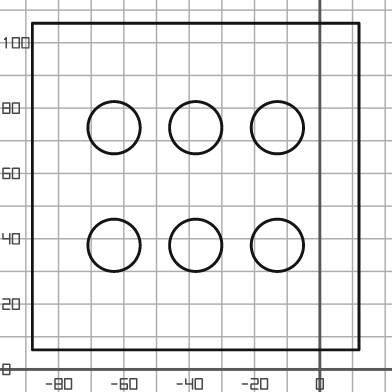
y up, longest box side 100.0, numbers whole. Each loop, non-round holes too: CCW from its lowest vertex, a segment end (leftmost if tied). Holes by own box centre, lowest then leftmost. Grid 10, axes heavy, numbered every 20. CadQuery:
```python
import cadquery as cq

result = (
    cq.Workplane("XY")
    .moveTo(-88.0, 6.0)
    .lineTo(12.0, 6.0)
    .lineTo(12.0, 106.0)
    .lineTo(-88.0, 106.0)
    .close()
    .moveTo(-63.0, 38.0)
    .circle(8.0)
    .moveTo(-38.0, 38.0)
    .circle(8.0)
    .moveTo(-13.0, 38.0)
    .circle(8.0)
    .moveTo(-63.0, 74.0)
    .circle(8.0)
    .moveTo(-38.0, 74.0)
    .circle(8.0)
    .moveTo(-13.0, 74.0)
    .circle(8.0)
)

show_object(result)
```